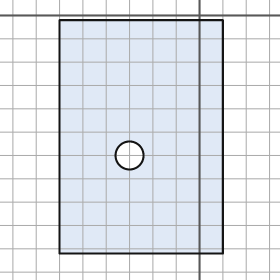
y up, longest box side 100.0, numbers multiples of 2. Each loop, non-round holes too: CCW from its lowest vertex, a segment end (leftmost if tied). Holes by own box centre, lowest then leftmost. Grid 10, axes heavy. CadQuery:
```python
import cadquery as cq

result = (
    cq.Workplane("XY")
    .moveTo(-60.0, -102.0)
    .lineTo(10.0, -102.0)
    .lineTo(10.0, -2.0)
    .lineTo(-60.0, -2.0)
    .close()
    .moveTo(-30.0, -60.0)
    .circle(6.0)
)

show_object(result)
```